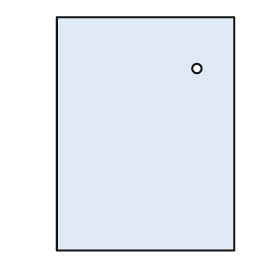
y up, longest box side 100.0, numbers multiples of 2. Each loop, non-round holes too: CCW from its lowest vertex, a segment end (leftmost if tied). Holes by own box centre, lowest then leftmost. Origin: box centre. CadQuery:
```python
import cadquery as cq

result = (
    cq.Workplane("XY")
    .moveTo(-38.0, -50.0)
    .lineTo(38.0, -50.0)
    .lineTo(38.0, 50.0)
    .lineTo(-38.0, 50.0)
    .close()
    .moveTo(22.0, 28.0)
    .circle(2.0)
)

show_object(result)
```